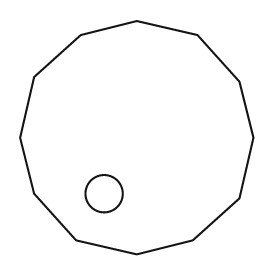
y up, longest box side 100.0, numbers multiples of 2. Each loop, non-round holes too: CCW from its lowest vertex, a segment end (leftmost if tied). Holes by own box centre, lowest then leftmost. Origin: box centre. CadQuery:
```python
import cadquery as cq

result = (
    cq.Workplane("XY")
    .moveTo(0.0, -50.0)
    .lineTo(24.0, -44.0)
    .lineTo(44.0, -26.0)
    .lineTo(50.0, 0.0)
    .lineTo(44.0, 24.0)
    .lineTo(26.0, 44.0)
    .lineTo(0.0, 50.0)
    .lineTo(-24.0, 44.0)
    .lineTo(-44.0, 26.0)
    .lineTo(-50.0, 0.0)
    .lineTo(-44.0, -24.0)
    .lineTo(-26.0, -44.0)
    .close()
    .moveTo(-14.0, -24.0)
    .circle(8.0)
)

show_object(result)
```